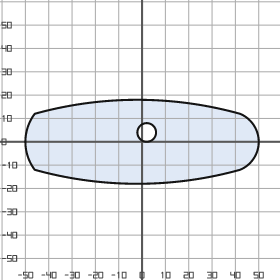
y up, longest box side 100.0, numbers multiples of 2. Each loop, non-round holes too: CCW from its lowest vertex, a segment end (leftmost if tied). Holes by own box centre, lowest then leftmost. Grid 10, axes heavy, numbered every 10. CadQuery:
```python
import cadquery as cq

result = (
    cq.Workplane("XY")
    .moveTo(-46.0, -12.0)
    .threePointArc((-2.0, -18.0), (42.0, -12.0))
    .threePointArc((50.0, 0.0), (42.0, 12.0))
    .threePointArc((-2.0, 18.0), (-46.0, 12.0))
    .threePointArc((-50.0, 0.0), (-46.0, -12.0))
    .close()
    .moveTo(2.0, 4.0)
    .circle(4.0)
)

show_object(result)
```